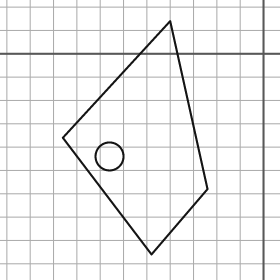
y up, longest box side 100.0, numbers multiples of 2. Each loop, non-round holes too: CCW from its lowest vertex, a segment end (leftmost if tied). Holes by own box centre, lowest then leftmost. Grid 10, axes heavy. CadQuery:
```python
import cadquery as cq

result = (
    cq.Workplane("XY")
    .moveTo(-48.0, -86.0)
    .lineTo(-24.0, -58.0)
    .lineTo(-40.0, 14.0)
    .lineTo(-86.0, -36.0)
    .close()
    .moveTo(-66.0, -44.0)
    .circle(6.0)
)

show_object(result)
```